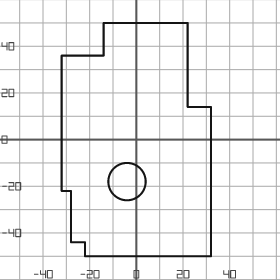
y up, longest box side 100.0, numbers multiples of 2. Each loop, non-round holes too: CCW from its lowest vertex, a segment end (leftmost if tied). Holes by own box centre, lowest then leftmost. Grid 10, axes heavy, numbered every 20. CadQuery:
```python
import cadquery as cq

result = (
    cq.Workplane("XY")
    .moveTo(-22.0, -50.0)
    .lineTo(32.0, -50.0)
    .lineTo(32.0, 14.0)
    .lineTo(22.0, 14.0)
    .lineTo(22.0, 50.0)
    .lineTo(-14.0, 50.0)
    .lineTo(-14.0, 36.0)
    .lineTo(-32.0, 36.0)
    .lineTo(-32.0, -22.0)
    .lineTo(-28.0, -22.0)
    .lineTo(-28.0, -44.0)
    .lineTo(-22.0, -44.0)
    .close()
    .moveTo(-4.0, -18.0)
    .circle(8.0)
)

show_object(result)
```